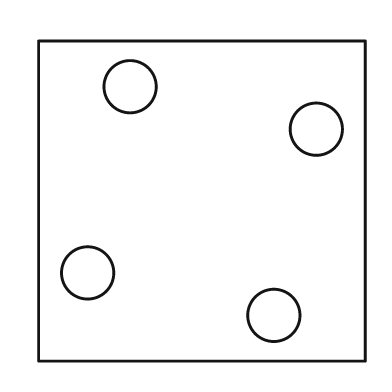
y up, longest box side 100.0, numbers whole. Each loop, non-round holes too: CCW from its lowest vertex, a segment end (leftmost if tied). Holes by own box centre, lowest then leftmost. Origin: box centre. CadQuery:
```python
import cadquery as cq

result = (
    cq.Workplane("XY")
    .moveTo(-50.0, -49.0)
    .lineTo(50.0, -49.0)
    .lineTo(50.0, 49.0)
    .lineTo(-50.0, 49.0)
    .close()
    .moveTo(22.0, -35.0)
    .circle(8.0)
    .moveTo(-35.0, -22.0)
    .circle(8.0)
    .moveTo(35.0, 22.0)
    .circle(8.0)
    .moveTo(-22.0, 35.0)
    .circle(8.0)
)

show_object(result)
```